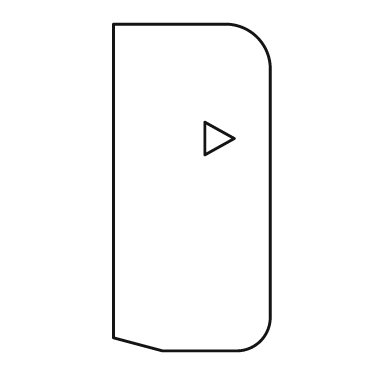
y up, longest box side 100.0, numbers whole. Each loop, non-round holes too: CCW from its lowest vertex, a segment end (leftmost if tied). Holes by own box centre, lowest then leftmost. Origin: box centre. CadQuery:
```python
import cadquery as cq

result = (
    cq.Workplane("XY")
    .moveTo(-9.0, -50.0)
    .lineTo(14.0, -50.0)
    .threePointArc((21.0, -47.0), (24.0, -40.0))
    .lineTo(24.0, 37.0)
    .threePointArc((20.0, 46.0), (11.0, 50.0))
    .lineTo(-24.0, 50.0)
    .lineTo(-24.0, -46.0)
    .close()
    .moveTo(4.0, 10.0)
    .lineTo(13.0, 15.0)
    .lineTo(4.0, 20.0)
    .close()
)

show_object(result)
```